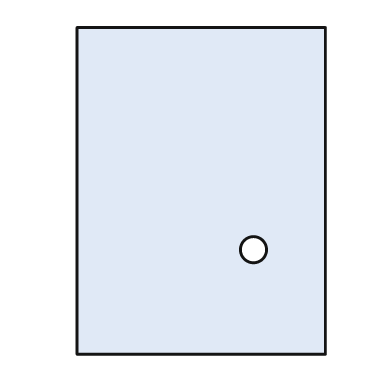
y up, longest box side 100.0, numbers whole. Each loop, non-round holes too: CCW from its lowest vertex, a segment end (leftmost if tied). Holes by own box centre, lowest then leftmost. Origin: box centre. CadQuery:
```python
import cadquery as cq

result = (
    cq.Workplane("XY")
    .moveTo(-38.0, -50.0)
    .lineTo(38.0, -50.0)
    .lineTo(38.0, 50.0)
    .lineTo(-38.0, 50.0)
    .close()
    .moveTo(16.0, -18.0)
    .circle(4.0)
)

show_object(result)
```